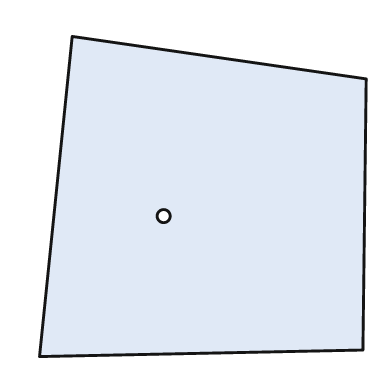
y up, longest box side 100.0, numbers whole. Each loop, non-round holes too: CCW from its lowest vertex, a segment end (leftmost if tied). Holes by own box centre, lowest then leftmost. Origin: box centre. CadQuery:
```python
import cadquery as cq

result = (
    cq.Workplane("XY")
    .moveTo(-50.0, -49.0)
    .lineTo(49.0, -47.0)
    .lineTo(50.0, 36.0)
    .lineTo(-40.0, 49.0)
    .close()
    .moveTo(-12.0, -6.0)
    .circle(2.0)
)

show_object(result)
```